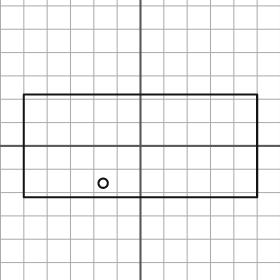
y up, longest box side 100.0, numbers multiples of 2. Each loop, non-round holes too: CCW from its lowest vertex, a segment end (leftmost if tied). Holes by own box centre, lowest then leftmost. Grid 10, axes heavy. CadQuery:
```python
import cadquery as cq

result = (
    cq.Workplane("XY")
    .moveTo(-50.0, -22.0)
    .lineTo(50.0, -22.0)
    .lineTo(50.0, 22.0)
    .lineTo(-50.0, 22.0)
    .close()
    .moveTo(-16.0, -16.0)
    .circle(2.0)
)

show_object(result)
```